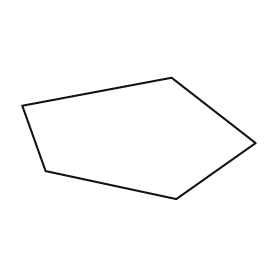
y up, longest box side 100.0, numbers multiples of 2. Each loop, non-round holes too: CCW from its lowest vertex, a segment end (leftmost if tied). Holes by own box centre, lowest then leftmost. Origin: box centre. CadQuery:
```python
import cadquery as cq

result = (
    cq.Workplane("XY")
    .moveTo(16.0, -26.0)
    .lineTo(50.0, -2.0)
    .lineTo(14.0, 26.0)
    .lineTo(-50.0, 14.0)
    .lineTo(-40.0, -14.0)
    .close()
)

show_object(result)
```